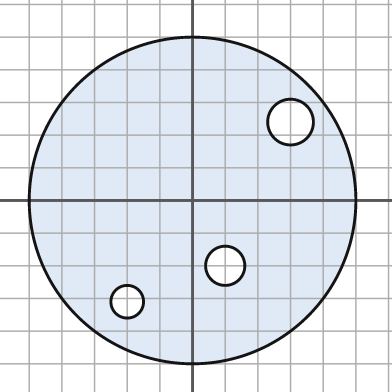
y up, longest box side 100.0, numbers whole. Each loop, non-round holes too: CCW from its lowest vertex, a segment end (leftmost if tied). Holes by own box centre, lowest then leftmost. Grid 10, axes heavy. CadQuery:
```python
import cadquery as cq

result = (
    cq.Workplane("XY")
    .moveTo(0.0, 0.0)
    .circle(50.0)
    .moveTo(-20.0, -31.0)
    .circle(5.0)
    .moveTo(10.0, -20.0)
    .circle(6.0)
    .moveTo(30.0, 24.0)
    .circle(7.0)
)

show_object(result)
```